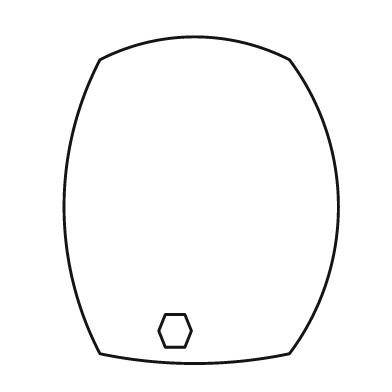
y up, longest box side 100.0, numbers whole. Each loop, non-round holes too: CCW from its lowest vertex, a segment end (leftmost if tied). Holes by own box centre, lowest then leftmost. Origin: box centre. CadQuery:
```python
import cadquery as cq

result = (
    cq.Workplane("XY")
    .moveTo(-31.0, -47.0)
    .threePointArc((-2.0, -50.0), (27.0, -47.0))
    .threePointArc((42.0, -2.0), (27.0, 43.0))
    .threePointArc((-2.0, 50.0), (-31.0, 43.0))
    .threePointArc((-42.0, -2.0), (-31.0, -47.0))
    .close()
    .moveTo(-11.0, -45.0)
    .lineTo(-5.0, -45.0)
    .lineTo(-3.0, -40.0)
    .lineTo(-5.0, -35.0)
    .lineTo(-11.0, -35.0)
    .lineTo(-13.0, -40.0)
    .close()
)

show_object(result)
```